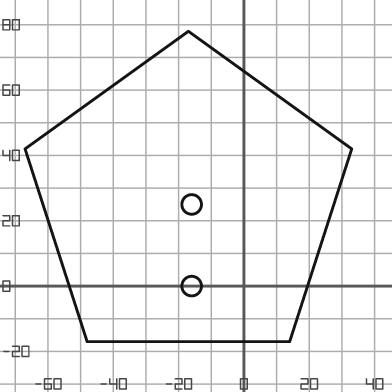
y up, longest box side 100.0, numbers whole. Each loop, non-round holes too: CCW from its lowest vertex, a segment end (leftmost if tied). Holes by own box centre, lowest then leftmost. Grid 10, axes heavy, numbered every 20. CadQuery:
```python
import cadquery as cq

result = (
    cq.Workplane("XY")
    .moveTo(-48.0, -17.0)
    .lineTo(14.0, -17.0)
    .lineTo(33.0, 42.0)
    .lineTo(-17.0, 78.0)
    .lineTo(-67.0, 42.0)
    .close()
    .moveTo(-16.0, 0.0)
    .circle(3.0)
    .moveTo(-16.0, 25.0)
    .circle(3.0)
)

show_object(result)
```